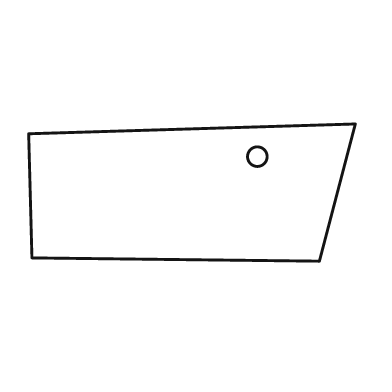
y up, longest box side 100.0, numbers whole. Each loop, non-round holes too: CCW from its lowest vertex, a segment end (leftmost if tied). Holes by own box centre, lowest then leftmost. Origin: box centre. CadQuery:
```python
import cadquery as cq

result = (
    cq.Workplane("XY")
    .moveTo(39.0, -21.0)
    .lineTo(50.0, 21.0)
    .lineTo(-50.0, 18.0)
    .lineTo(-49.0, -20.0)
    .close()
    .moveTo(20.0, 11.0)
    .circle(3.0)
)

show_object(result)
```